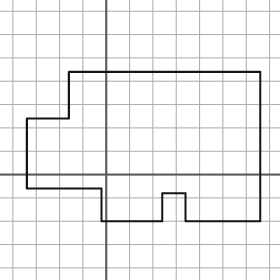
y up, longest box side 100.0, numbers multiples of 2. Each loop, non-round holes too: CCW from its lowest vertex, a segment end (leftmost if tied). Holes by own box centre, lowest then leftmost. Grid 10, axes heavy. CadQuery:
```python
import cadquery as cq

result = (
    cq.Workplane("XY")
    .moveTo(-2.0, -20.0)
    .lineTo(24.0, -20.0)
    .lineTo(24.0, -8.0)
    .lineTo(34.0, -8.0)
    .lineTo(34.0, -20.0)
    .lineTo(66.0, -20.0)
    .lineTo(66.0, 44.0)
    .lineTo(-16.0, 44.0)
    .lineTo(-16.0, 24.0)
    .lineTo(-34.0, 24.0)
    .lineTo(-34.0, -6.0)
    .lineTo(-2.0, -6.0)
    .close()
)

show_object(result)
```